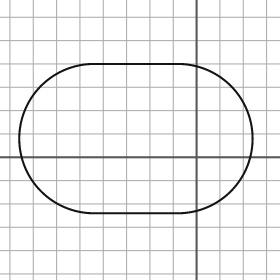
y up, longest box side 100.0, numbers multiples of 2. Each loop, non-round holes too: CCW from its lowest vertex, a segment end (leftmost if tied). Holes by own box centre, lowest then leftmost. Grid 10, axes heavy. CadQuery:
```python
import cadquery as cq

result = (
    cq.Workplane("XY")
    .moveTo(-44.0, -24.0)
    .lineTo(-8.0, -24.0)
    .threePointArc((24.0, 8.0), (-8.0, 40.0))
    .lineTo(-44.0, 40.0)
    .threePointArc((-76.0, 8.0), (-44.0, -24.0))
    .close()
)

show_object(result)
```